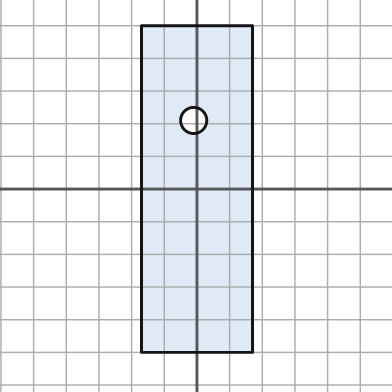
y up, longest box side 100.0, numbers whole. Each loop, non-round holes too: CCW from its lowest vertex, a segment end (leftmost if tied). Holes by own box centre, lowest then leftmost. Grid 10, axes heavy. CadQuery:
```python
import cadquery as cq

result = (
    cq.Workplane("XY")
    .moveTo(-17.0, -50.0)
    .lineTo(17.0, -50.0)
    .lineTo(17.0, 50.0)
    .lineTo(-17.0, 50.0)
    .close()
    .moveTo(-1.0, 21.0)
    .circle(4.0)
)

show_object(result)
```